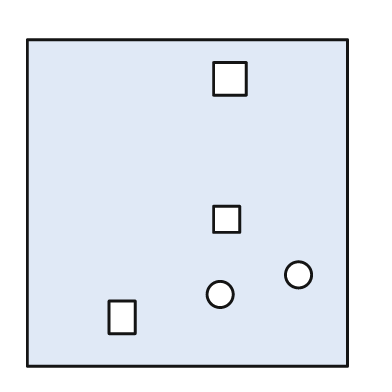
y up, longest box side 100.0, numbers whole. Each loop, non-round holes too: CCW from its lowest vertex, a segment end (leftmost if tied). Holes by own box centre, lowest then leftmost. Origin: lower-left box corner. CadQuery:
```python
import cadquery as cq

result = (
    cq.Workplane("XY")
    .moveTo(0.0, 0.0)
    .lineTo(98.0, 0.0)
    .lineTo(98.0, 100.0)
    .lineTo(0.0, 100.0)
    .close()
    .moveTo(25.0, 10.0)
    .lineTo(33.0, 10.0)
    .lineTo(33.0, 20.0)
    .lineTo(25.0, 20.0)
    .close()
    .moveTo(59.0, 22.0)
    .circle(4.0)
    .moveTo(83.0, 28.0)
    .circle(4.0)
    .moveTo(57.0, 41.0)
    .lineTo(65.0, 41.0)
    .lineTo(65.0, 49.0)
    .lineTo(57.0, 49.0)
    .close()
    .moveTo(57.0, 83.0)
    .lineTo(67.0, 83.0)
    .lineTo(67.0, 93.0)
    .lineTo(57.0, 93.0)
    .close()
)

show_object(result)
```